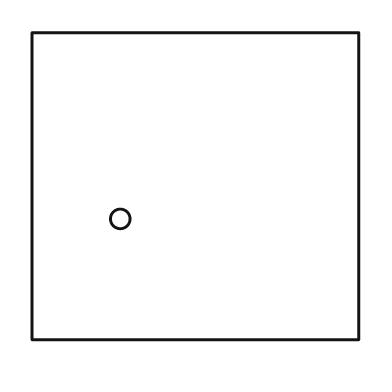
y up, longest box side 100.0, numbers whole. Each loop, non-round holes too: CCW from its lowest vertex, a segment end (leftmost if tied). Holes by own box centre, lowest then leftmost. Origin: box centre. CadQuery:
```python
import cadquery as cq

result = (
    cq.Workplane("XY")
    .moveTo(-50.0, -47.0)
    .lineTo(50.0, -47.0)
    .lineTo(50.0, 47.0)
    .lineTo(-50.0, 47.0)
    .close()
    .moveTo(-23.0, -10.0)
    .circle(3.0)
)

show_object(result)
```